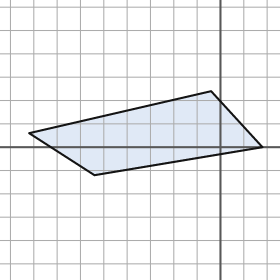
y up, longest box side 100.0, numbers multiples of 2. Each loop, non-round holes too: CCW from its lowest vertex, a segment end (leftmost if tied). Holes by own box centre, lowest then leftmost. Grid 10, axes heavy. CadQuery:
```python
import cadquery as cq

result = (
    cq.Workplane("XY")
    .moveTo(-54.0, -12.0)
    .lineTo(18.0, 0.0)
    .lineTo(-4.0, 24.0)
    .lineTo(-82.0, 6.0)
    .close()
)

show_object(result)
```